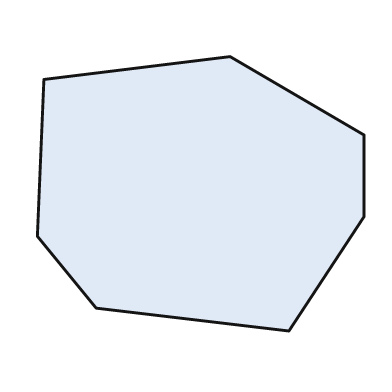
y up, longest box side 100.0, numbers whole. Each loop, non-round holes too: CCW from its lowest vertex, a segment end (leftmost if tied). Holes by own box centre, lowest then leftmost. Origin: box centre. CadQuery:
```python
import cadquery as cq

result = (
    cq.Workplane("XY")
    .moveTo(27.0, -42.0)
    .lineTo(50.0, -7.0)
    .lineTo(50.0, 18.0)
    .lineTo(9.0, 42.0)
    .lineTo(-48.0, 35.0)
    .lineTo(-50.0, -13.0)
    .lineTo(-32.0, -35.0)
    .close()
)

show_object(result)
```